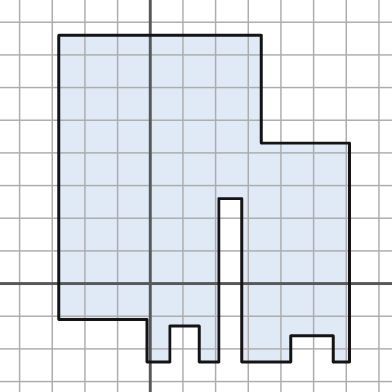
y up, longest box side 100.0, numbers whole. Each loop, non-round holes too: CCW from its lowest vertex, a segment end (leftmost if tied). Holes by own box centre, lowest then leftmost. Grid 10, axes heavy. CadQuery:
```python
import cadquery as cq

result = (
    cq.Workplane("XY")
    .moveTo(-1.0, -24.0)
    .lineTo(6.0, -24.0)
    .lineTo(6.0, -13.0)
    .lineTo(15.0, -13.0)
    .lineTo(15.0, -24.0)
    .lineTo(21.0, -24.0)
    .lineTo(21.0, 26.0)
    .lineTo(28.0, 26.0)
    .lineTo(28.0, -24.0)
    .lineTo(43.0, -24.0)
    .lineTo(43.0, -16.0)
    .lineTo(56.0, -16.0)
    .lineTo(56.0, -24.0)
    .lineTo(61.0, -24.0)
    .lineTo(61.0, 43.0)
    .lineTo(34.0, 43.0)
    .lineTo(34.0, 76.0)
    .lineTo(-28.0, 76.0)
    .lineTo(-28.0, -11.0)
    .lineTo(-1.0, -11.0)
    .close()
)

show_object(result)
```